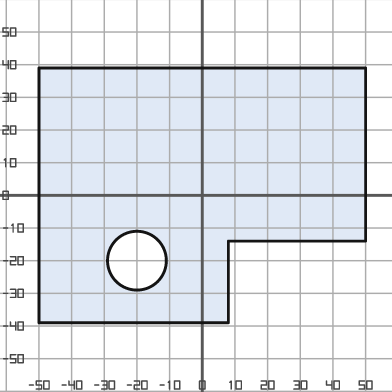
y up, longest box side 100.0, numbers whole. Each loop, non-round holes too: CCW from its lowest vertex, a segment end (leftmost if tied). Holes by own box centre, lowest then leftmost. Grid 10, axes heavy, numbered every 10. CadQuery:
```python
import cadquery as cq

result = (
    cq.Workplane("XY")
    .moveTo(-50.0, -39.0)
    .lineTo(8.0, -39.0)
    .lineTo(8.0, -14.0)
    .lineTo(50.0, -14.0)
    .lineTo(50.0, 39.0)
    .lineTo(-50.0, 39.0)
    .close()
    .moveTo(-20.0, -20.0)
    .circle(9.0)
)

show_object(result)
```